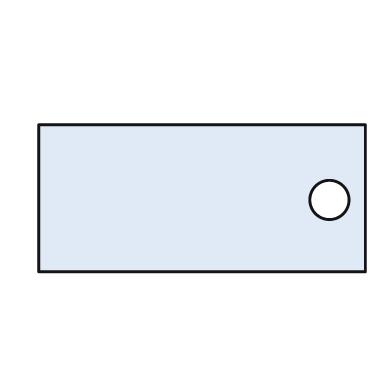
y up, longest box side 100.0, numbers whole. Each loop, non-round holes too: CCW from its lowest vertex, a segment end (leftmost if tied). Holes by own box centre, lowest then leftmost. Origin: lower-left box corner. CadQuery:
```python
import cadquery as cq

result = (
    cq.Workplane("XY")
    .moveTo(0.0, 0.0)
    .lineTo(100.0, 0.0)
    .lineTo(100.0, 45.0)
    .lineTo(0.0, 45.0)
    .close()
    .moveTo(89.0, 22.0)
    .circle(6.0)
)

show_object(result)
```